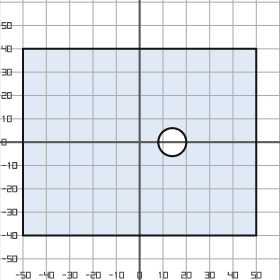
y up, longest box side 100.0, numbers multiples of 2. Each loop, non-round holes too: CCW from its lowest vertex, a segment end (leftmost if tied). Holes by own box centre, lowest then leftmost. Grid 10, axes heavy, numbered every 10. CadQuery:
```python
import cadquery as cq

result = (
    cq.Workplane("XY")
    .moveTo(-50.0, -40.0)
    .lineTo(50.0, -40.0)
    .lineTo(50.0, 40.0)
    .lineTo(-50.0, 40.0)
    .close()
    .moveTo(14.0, 0.0)
    .circle(6.0)
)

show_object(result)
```